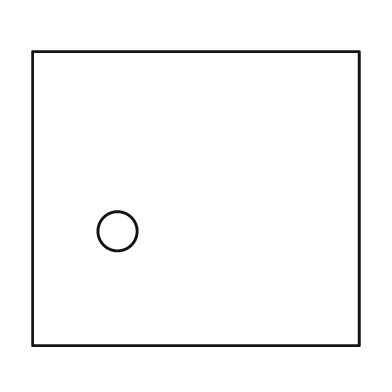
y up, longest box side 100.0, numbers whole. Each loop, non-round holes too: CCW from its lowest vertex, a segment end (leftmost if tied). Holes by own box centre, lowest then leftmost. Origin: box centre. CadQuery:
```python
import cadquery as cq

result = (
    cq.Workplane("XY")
    .moveTo(-50.0, -45.0)
    .lineTo(50.0, -45.0)
    .lineTo(50.0, 45.0)
    .lineTo(-50.0, 45.0)
    .close()
    .moveTo(-24.0, -10.0)
    .circle(6.0)
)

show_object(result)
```